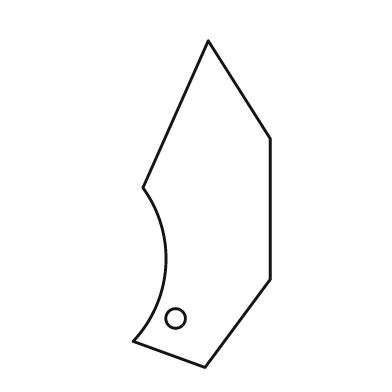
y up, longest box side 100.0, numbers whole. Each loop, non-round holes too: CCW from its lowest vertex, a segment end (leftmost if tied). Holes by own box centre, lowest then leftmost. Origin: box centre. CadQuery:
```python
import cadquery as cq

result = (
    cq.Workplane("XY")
    .moveTo(1.0, -50.0)
    .lineTo(21.0, -23.0)
    .lineTo(21.0, 20.0)
    .lineTo(2.0, 50.0)
    .lineTo(-18.0, 5.0)
    .threePointArc((-11.0, -19.0), (-21.0, -42.0))
    .close()
    .moveTo(-8.0, -35.0)
    .circle(3.0)
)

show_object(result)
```